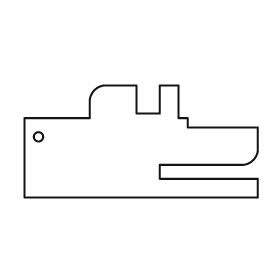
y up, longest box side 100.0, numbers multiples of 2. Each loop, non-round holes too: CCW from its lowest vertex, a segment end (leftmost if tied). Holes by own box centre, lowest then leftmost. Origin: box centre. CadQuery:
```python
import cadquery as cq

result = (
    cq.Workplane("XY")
    .moveTo(-50.0, -24.0)
    .lineTo(50.0, -24.0)
    .lineTo(50.0, -16.0)
    .lineTo(8.0, -16.0)
    .lineTo(8.0, -10.0)
    .lineTo(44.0, -10.0)
    .threePointArc((48.0, -8.0), (50.0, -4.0))
    .lineTo(50.0, 6.0)
    .lineTo(20.0, 6.0)
    .lineTo(20.0, 10.0)
    .lineTo(16.0, 10.0)
    .lineTo(16.0, 24.0)
    .lineTo(8.0, 24.0)
    .lineTo(8.0, 12.0)
    .lineTo(-2.0, 12.0)
    .lineTo(-2.0, 24.0)
    .lineTo(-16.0, 24.0)
    .threePointArc((-20.0, 22.0), (-22.0, 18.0))
    .lineTo(-22.0, 10.0)
    .lineTo(-50.0, 10.0)
    .close()
    .moveTo(-44.0, 2.0)
    .circle(2.0)
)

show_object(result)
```